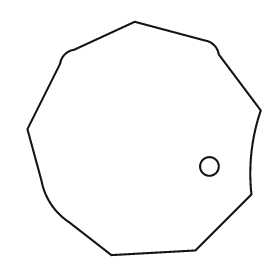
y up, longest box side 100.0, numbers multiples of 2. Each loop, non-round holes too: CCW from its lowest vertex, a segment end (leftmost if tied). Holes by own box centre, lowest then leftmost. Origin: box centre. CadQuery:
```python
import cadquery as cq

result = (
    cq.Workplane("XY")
    .moveTo(-14.0, -50.0)
    .lineTo(22.0, -48.0)
    .lineTo(46.0, -24.0)
    .threePointArc((46.0, -6.0), (50.0, 12.0))
    .lineTo(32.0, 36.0)
    .threePointArc((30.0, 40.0), (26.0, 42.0))
    .lineTo(-4.0, 50.0)
    .lineTo(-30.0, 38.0)
    .threePointArc((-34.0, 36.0), (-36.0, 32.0))
    .lineTo(-50.0, 4.0)
    .lineTo(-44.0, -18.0)
    .threePointArc((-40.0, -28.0), (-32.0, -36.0))
    .close()
    .moveTo(28.0, -12.0)
    .circle(4.0)
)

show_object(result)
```